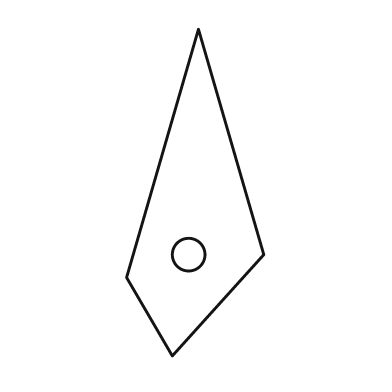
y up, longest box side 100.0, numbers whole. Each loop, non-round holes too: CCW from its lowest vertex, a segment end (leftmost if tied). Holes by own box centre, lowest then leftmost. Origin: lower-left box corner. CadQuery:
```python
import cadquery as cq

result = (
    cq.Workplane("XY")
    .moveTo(14.0, 0.0)
    .lineTo(42.0, 31.0)
    .lineTo(22.0, 100.0)
    .lineTo(0.0, 24.0)
    .close()
    .moveTo(19.0, 31.0)
    .circle(5.0)
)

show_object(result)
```